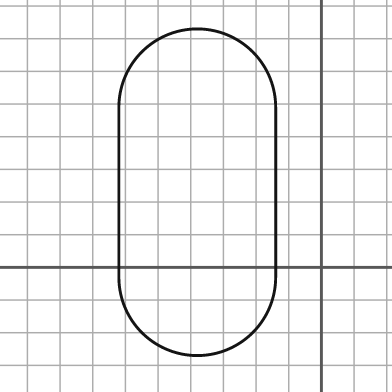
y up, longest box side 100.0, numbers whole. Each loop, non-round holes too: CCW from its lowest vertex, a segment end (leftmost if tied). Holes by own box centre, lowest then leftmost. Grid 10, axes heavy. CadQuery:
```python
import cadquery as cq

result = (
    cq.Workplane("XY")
    .moveTo(-62.0, -3.0)
    .threePointArc((-38.0, -27.0), (-14.0, -3.0))
    .lineTo(-14.0, 49.0)
    .threePointArc((-38.0, 73.0), (-62.0, 49.0))
    .close()
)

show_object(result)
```